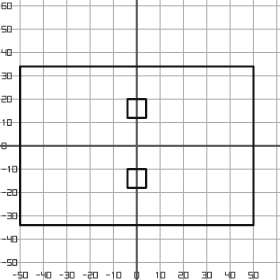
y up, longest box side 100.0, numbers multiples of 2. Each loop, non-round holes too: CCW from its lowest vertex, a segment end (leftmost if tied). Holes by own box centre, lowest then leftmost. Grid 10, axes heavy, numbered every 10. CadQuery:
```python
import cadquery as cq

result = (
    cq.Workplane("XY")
    .moveTo(-50.0, -34.0)
    .lineTo(50.0, -34.0)
    .lineTo(50.0, 34.0)
    .lineTo(-50.0, 34.0)
    .close()
    .moveTo(-4.0, -18.0)
    .lineTo(4.0, -18.0)
    .lineTo(4.0, -10.0)
    .lineTo(-4.0, -10.0)
    .close()
    .moveTo(-4.0, 12.0)
    .lineTo(4.0, 12.0)
    .lineTo(4.0, 20.0)
    .lineTo(-4.0, 20.0)
    .close()
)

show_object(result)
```